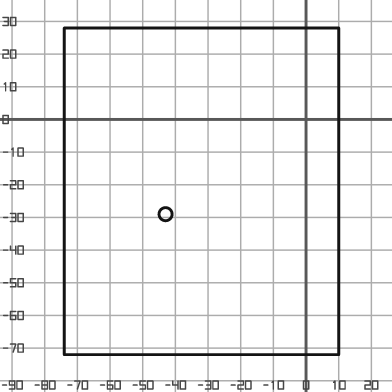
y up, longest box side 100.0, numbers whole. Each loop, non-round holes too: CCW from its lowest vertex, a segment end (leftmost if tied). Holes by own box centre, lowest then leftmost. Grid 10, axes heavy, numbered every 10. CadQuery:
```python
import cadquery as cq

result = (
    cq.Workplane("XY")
    .moveTo(-74.0, -72.0)
    .lineTo(10.0, -72.0)
    .lineTo(10.0, 28.0)
    .lineTo(-74.0, 28.0)
    .close()
    .moveTo(-43.0, -29.0)
    .circle(2.0)
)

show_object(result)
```